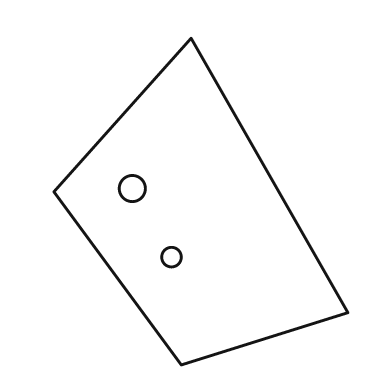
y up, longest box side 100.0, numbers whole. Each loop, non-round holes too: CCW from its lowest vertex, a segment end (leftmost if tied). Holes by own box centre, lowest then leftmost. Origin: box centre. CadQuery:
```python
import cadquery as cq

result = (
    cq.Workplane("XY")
    .moveTo(-6.0, -50.0)
    .lineTo(45.0, -34.0)
    .lineTo(-3.0, 50.0)
    .lineTo(-45.0, 3.0)
    .close()
    .moveTo(-9.0, -17.0)
    .circle(3.0)
    .moveTo(-21.0, 4.0)
    .circle(4.0)
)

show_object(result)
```